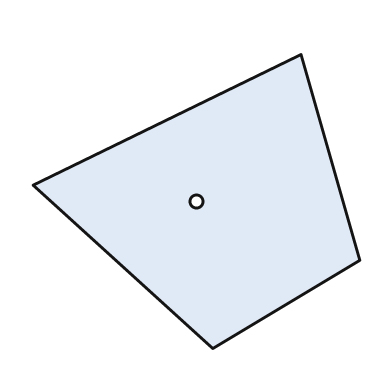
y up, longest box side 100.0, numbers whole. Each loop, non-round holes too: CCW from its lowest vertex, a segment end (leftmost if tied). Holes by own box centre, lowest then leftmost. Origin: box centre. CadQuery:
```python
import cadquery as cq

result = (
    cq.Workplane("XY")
    .moveTo(5.0, -45.0)
    .lineTo(50.0, -18.0)
    .lineTo(32.0, 45.0)
    .lineTo(-50.0, 5.0)
    .close()
    .moveTo(0.0, 0.0)
    .circle(2.0)
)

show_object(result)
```